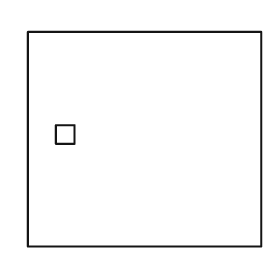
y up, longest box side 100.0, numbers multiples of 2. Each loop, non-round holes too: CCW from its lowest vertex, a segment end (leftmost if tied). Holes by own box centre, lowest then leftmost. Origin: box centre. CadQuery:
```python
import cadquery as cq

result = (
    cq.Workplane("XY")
    .moveTo(-50.0, -46.0)
    .lineTo(50.0, -46.0)
    .lineTo(50.0, 46.0)
    .lineTo(-50.0, 46.0)
    .close()
    .moveTo(-38.0, -2.0)
    .lineTo(-30.0, -2.0)
    .lineTo(-30.0, 6.0)
    .lineTo(-38.0, 6.0)
    .close()
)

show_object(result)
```